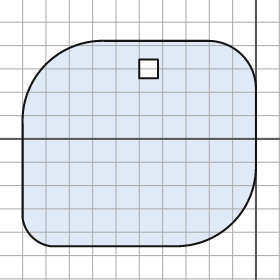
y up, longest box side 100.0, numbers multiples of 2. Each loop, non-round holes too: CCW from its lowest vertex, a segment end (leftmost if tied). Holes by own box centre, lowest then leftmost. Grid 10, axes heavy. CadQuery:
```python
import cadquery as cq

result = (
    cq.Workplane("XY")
    .moveTo(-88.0, -46.0)
    .lineTo(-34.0, -46.0)
    .threePointArc((-10.0, -36.0), (0.0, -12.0))
    .lineTo(0.0, 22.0)
    .threePointArc((-6.0, 36.0), (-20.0, 42.0))
    .lineTo(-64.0, 42.0)
    .threePointArc((-90.0, 32.0), (-100.0, 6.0))
    .lineTo(-100.0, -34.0)
    .threePointArc((-96.0, -42.0), (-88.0, -46.0))
    .close()
    .moveTo(-50.0, 26.0)
    .lineTo(-42.0, 26.0)
    .lineTo(-42.0, 34.0)
    .lineTo(-50.0, 34.0)
    .close()
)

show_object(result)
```